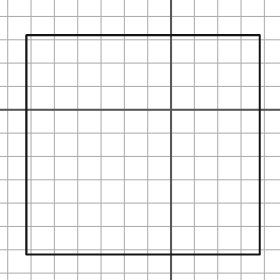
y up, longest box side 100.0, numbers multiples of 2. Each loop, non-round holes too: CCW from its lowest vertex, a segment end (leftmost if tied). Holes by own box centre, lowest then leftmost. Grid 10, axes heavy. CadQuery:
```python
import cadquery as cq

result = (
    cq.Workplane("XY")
    .moveTo(-62.0, -62.0)
    .lineTo(38.0, -62.0)
    .lineTo(38.0, 32.0)
    .lineTo(-62.0, 32.0)
    .close()
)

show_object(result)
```